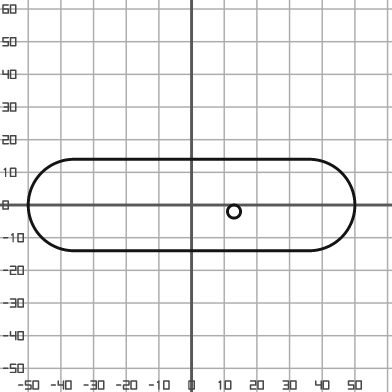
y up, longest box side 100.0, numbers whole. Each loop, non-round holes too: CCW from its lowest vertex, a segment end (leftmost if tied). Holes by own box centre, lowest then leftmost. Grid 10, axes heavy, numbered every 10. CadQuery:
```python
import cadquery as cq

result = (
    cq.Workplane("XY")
    .moveTo(-36.0, -14.0)
    .lineTo(36.0, -14.0)
    .threePointArc((50.0, 0.0), (36.0, 14.0))
    .lineTo(-36.0, 14.0)
    .threePointArc((-50.0, 0.0), (-36.0, -14.0))
    .close()
    .moveTo(13.0, -2.0)
    .circle(2.0)
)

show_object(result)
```